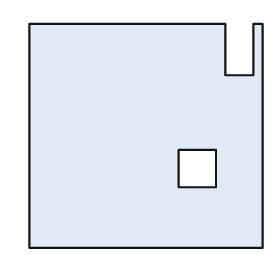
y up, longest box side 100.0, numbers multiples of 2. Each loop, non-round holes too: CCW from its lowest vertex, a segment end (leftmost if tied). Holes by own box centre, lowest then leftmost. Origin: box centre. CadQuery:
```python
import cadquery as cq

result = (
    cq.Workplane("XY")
    .moveTo(-50.0, -48.0)
    .lineTo(50.0, -48.0)
    .lineTo(50.0, 48.0)
    .lineTo(46.0, 48.0)
    .lineTo(46.0, 26.0)
    .lineTo(34.0, 26.0)
    .lineTo(34.0, 48.0)
    .lineTo(-50.0, 48.0)
    .close()
    .moveTo(14.0, -22.0)
    .lineTo(30.0, -22.0)
    .lineTo(30.0, -6.0)
    .lineTo(14.0, -6.0)
    .close()
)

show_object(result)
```